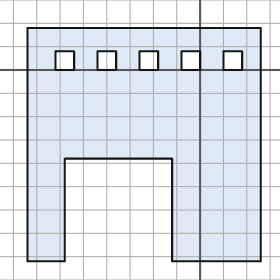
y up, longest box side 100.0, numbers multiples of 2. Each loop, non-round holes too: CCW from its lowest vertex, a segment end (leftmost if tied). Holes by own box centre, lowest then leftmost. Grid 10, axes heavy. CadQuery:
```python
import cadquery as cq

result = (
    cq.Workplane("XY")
    .moveTo(-74.0, -82.0)
    .lineTo(-58.0, -82.0)
    .lineTo(-58.0, -38.0)
    .lineTo(-12.0, -38.0)
    .lineTo(-12.0, -82.0)
    .lineTo(26.0, -82.0)
    .lineTo(26.0, 18.0)
    .lineTo(-74.0, 18.0)
    .close()
    .moveTo(-62.0, 0.0)
    .lineTo(-54.0, 0.0)
    .lineTo(-54.0, 8.0)
    .lineTo(-62.0, 8.0)
    .close()
    .moveTo(-44.0, 0.0)
    .lineTo(-36.0, 0.0)
    .lineTo(-36.0, 8.0)
    .lineTo(-44.0, 8.0)
    .close()
    .moveTo(-26.0, 0.0)
    .lineTo(-18.0, 0.0)
    .lineTo(-18.0, 8.0)
    .lineTo(-26.0, 8.0)
    .close()
    .moveTo(-8.0, 0.0)
    .lineTo(0.0, 0.0)
    .lineTo(0.0, 8.0)
    .lineTo(-8.0, 8.0)
    .close()
    .moveTo(10.0, 0.0)
    .lineTo(18.0, 0.0)
    .lineTo(18.0, 8.0)
    .lineTo(10.0, 8.0)
    .close()
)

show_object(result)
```